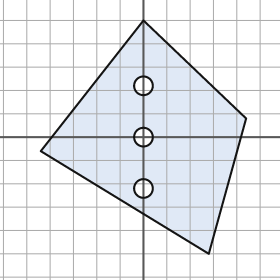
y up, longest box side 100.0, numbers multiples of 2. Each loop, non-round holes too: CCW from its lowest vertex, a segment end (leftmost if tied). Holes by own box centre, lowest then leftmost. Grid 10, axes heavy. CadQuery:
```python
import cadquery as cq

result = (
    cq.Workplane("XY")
    .moveTo(28.0, -50.0)
    .lineTo(44.0, 8.0)
    .lineTo(0.0, 50.0)
    .lineTo(-44.0, -6.0)
    .close()
    .moveTo(0.0, -22.0)
    .circle(4.0)
    .moveTo(0.0, 0.0)
    .circle(4.0)
    .moveTo(0.0, 22.0)
    .circle(4.0)
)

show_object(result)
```